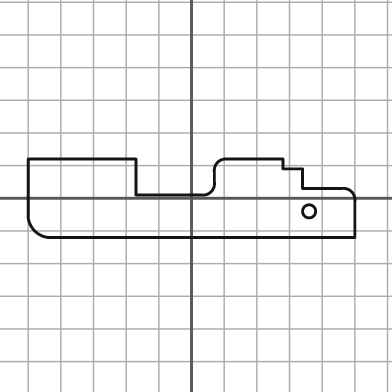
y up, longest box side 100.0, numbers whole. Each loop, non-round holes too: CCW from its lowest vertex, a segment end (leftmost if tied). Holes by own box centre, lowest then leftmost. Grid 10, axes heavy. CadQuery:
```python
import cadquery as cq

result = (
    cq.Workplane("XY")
    .moveTo(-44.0, -12.0)
    .lineTo(50.0, -12.0)
    .lineTo(50.0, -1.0)
    .threePointArc((49.0, 2.0), (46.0, 3.0))
    .lineTo(34.0, 3.0)
    .lineTo(34.0, 9.0)
    .lineTo(28.0, 9.0)
    .lineTo(28.0, 12.0)
    .lineTo(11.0, 12.0)
    .threePointArc((8.0, 11.0), (7.0, 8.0))
    .lineTo(7.0, 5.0)
    .threePointArc((6.0, 2.0), (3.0, 1.0))
    .lineTo(-17.0, 1.0)
    .lineTo(-17.0, 12.0)
    .lineTo(-50.0, 12.0)
    .lineTo(-50.0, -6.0)
    .threePointArc((-48.0, -10.0), (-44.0, -12.0))
    .close()
    .moveTo(36.0, -4.0)
    .circle(2.0)
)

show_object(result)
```